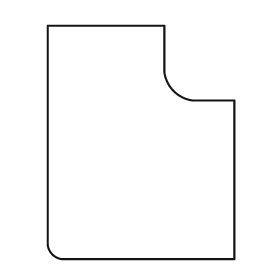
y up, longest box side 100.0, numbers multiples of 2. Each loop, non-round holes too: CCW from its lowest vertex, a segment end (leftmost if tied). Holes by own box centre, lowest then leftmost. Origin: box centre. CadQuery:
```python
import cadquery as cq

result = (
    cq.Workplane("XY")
    .moveTo(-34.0, -50.0)
    .lineTo(40.0, -50.0)
    .lineTo(40.0, 18.0)
    .lineTo(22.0, 18.0)
    .threePointArc((14.0, 22.0), (10.0, 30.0))
    .lineTo(10.0, 50.0)
    .lineTo(-40.0, 50.0)
    .lineTo(-40.0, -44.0)
    .threePointArc((-38.0, -48.0), (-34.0, -50.0))
    .close()
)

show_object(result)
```